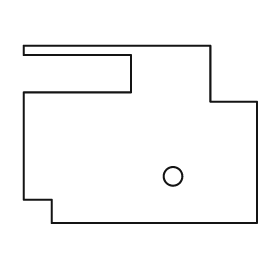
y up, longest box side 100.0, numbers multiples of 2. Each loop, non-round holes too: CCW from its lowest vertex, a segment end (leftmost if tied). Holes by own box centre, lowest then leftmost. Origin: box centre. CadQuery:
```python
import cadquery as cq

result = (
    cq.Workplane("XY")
    .moveTo(-38.0, -38.0)
    .lineTo(50.0, -38.0)
    .lineTo(50.0, 14.0)
    .lineTo(30.0, 14.0)
    .lineTo(30.0, 38.0)
    .lineTo(-50.0, 38.0)
    .lineTo(-50.0, 34.0)
    .lineTo(-4.0, 34.0)
    .lineTo(-4.0, 18.0)
    .lineTo(-50.0, 18.0)
    .lineTo(-50.0, -28.0)
    .lineTo(-38.0, -28.0)
    .close()
    .moveTo(14.0, -18.0)
    .circle(4.0)
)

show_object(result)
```